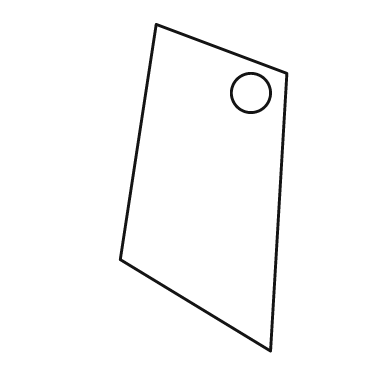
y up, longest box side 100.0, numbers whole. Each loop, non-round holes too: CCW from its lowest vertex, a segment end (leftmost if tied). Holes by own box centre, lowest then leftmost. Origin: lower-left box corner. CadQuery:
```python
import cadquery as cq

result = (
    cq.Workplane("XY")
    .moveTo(46.0, 0.0)
    .lineTo(51.0, 85.0)
    .lineTo(11.0, 100.0)
    .lineTo(0.0, 28.0)
    .close()
    .moveTo(40.0, 79.0)
    .circle(6.0)
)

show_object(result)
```